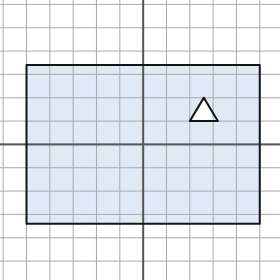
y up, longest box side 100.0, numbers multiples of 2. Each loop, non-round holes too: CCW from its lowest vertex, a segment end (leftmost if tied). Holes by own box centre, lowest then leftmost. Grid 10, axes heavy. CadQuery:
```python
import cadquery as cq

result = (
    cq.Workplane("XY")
    .moveTo(-50.0, -34.0)
    .lineTo(50.0, -34.0)
    .lineTo(50.0, 34.0)
    .lineTo(-50.0, 34.0)
    .close()
    .moveTo(20.0, 10.0)
    .lineTo(32.0, 10.0)
    .lineTo(26.0, 20.0)
    .close()
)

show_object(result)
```